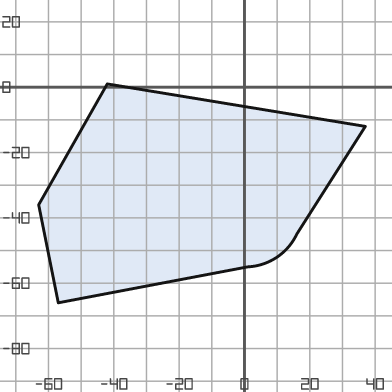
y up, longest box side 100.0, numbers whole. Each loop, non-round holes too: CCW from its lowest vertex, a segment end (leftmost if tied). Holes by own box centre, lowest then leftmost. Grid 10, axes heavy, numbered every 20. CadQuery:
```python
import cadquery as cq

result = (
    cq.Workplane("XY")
    .moveTo(-57.0, -66.0)
    .lineTo(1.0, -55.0)
    .threePointArc((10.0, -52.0), (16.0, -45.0))
    .lineTo(37.0, -12.0)
    .lineTo(-42.0, 1.0)
    .lineTo(-63.0, -36.0)
    .close()
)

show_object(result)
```